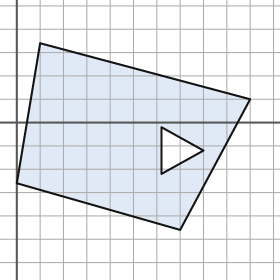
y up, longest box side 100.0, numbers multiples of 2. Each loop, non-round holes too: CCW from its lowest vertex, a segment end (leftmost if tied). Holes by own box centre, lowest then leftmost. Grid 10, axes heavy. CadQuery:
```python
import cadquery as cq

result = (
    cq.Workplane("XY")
    .moveTo(70.0, -46.0)
    .lineTo(100.0, 10.0)
    .lineTo(10.0, 34.0)
    .lineTo(0.0, -26.0)
    .close()
    .moveTo(62.0, -22.0)
    .lineTo(80.0, -12.0)
    .lineTo(62.0, -2.0)
    .close()
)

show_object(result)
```